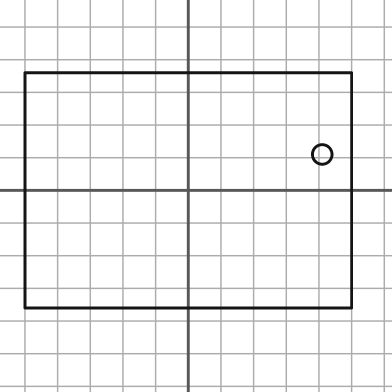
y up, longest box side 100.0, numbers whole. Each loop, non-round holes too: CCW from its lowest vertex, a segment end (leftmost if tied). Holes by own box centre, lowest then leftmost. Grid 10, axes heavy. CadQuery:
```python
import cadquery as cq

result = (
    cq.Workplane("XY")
    .moveTo(-50.0, -36.0)
    .lineTo(50.0, -36.0)
    .lineTo(50.0, 36.0)
    .lineTo(-50.0, 36.0)
    .close()
    .moveTo(41.0, 11.0)
    .circle(3.0)
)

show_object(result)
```